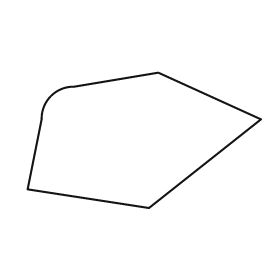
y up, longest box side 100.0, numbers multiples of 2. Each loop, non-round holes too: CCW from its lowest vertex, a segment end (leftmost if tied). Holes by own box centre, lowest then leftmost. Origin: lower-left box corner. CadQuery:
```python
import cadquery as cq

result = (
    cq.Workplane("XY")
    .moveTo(52.0, 0.0)
    .lineTo(100.0, 38.0)
    .lineTo(56.0, 58.0)
    .lineTo(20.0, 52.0)
    .threePointArc((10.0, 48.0), (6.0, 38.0))
    .lineTo(0.0, 8.0)
    .close()
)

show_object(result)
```